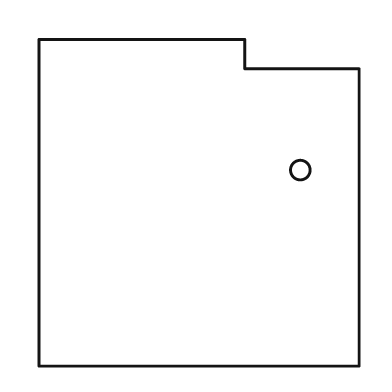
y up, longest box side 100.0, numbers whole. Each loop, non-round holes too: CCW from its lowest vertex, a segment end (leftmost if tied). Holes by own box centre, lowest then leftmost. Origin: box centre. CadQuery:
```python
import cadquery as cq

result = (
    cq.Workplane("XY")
    .moveTo(-49.0, -50.0)
    .lineTo(49.0, -50.0)
    .lineTo(49.0, 41.0)
    .lineTo(14.0, 41.0)
    .lineTo(14.0, 50.0)
    .lineTo(-49.0, 50.0)
    .close()
    .moveTo(31.0, 10.0)
    .circle(3.0)
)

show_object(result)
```